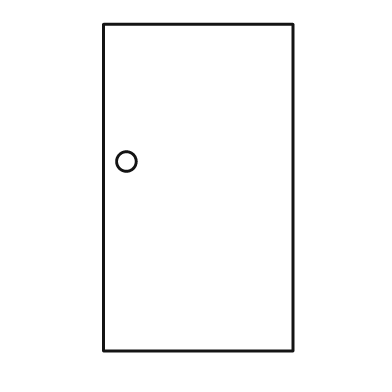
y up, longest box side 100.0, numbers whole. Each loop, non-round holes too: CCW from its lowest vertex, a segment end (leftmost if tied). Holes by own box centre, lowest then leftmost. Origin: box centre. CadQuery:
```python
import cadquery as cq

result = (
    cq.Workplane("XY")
    .moveTo(-29.0, -50.0)
    .lineTo(29.0, -50.0)
    .lineTo(29.0, 50.0)
    .lineTo(-29.0, 50.0)
    .close()
    .moveTo(-22.0, 8.0)
    .circle(3.0)
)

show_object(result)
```